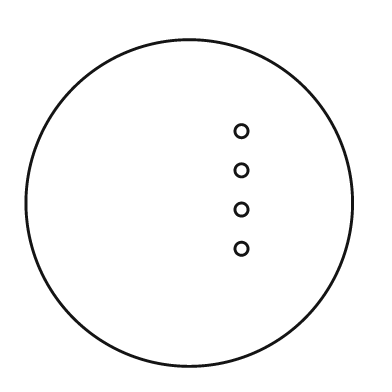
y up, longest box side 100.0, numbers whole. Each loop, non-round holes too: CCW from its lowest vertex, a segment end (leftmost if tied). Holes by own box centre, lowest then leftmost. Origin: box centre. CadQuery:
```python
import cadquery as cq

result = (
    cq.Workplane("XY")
    .moveTo(0.0, 0.0)
    .circle(50.0)
    .moveTo(16.0, -14.0)
    .circle(2.0)
    .moveTo(16.0, -2.0)
    .circle(2.0)
    .moveTo(16.0, 10.0)
    .circle(2.0)
    .moveTo(16.0, 22.0)
    .circle(2.0)
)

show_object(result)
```